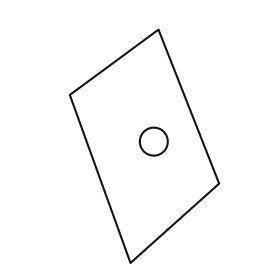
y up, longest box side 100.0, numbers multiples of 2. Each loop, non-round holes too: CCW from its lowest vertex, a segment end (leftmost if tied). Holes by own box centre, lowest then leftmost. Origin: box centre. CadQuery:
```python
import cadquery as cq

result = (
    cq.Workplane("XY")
    .moveTo(-6.0, -50.0)
    .lineTo(32.0, -16.0)
    .lineTo(6.0, 50.0)
    .lineTo(-32.0, 22.0)
    .close()
    .moveTo(4.0, 2.0)
    .circle(6.0)
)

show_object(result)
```